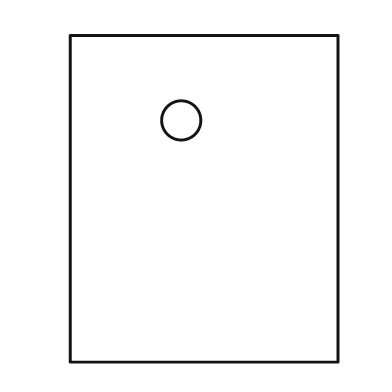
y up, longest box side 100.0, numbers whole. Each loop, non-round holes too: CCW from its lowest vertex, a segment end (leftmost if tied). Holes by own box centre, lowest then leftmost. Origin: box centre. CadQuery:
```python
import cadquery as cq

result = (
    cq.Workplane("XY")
    .moveTo(-41.0, -50.0)
    .lineTo(41.0, -50.0)
    .lineTo(41.0, 50.0)
    .lineTo(-41.0, 50.0)
    .close()
    .moveTo(-7.0, 24.0)
    .circle(6.0)
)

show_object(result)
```